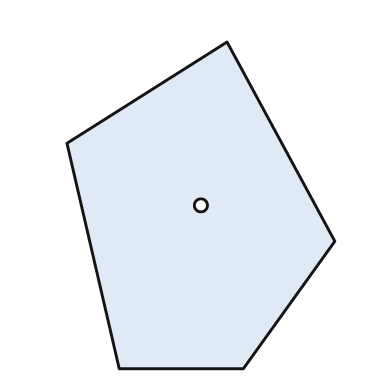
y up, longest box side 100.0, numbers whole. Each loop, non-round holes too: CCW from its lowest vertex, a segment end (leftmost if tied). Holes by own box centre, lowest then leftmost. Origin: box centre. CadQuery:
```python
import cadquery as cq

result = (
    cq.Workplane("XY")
    .moveTo(-25.0, -50.0)
    .lineTo(13.0, -50.0)
    .lineTo(41.0, -11.0)
    .lineTo(8.0, 50.0)
    .lineTo(-41.0, 19.0)
    .close()
    .moveTo(0.0, 0.0)
    .circle(2.0)
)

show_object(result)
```